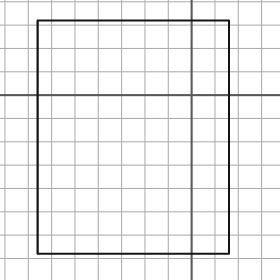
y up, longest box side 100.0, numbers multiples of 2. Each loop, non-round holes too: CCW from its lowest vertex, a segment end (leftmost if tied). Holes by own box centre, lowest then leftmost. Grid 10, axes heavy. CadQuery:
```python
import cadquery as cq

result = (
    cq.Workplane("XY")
    .moveTo(-66.0, -68.0)
    .lineTo(16.0, -68.0)
    .lineTo(16.0, 32.0)
    .lineTo(-66.0, 32.0)
    .close()
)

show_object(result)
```